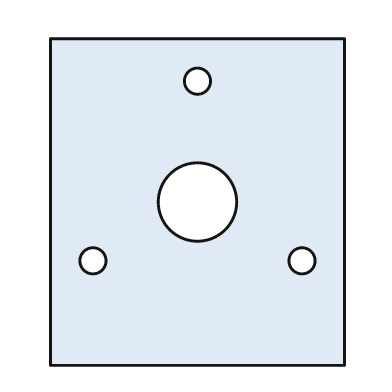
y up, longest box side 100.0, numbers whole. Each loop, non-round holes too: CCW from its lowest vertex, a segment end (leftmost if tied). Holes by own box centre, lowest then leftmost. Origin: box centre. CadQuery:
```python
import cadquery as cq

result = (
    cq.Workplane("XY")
    .moveTo(-45.0, -50.0)
    .lineTo(45.0, -50.0)
    .lineTo(45.0, 50.0)
    .lineTo(-45.0, 50.0)
    .close()
    .moveTo(-32.0, -18.0)
    .circle(4.0)
    .moveTo(32.0, -18.0)
    .circle(4.0)
    .moveTo(0.0, 0.0)
    .circle(12.0)
    .moveTo(0.0, 37.0)
    .circle(4.0)
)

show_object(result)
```